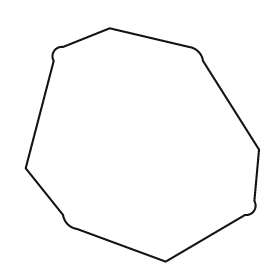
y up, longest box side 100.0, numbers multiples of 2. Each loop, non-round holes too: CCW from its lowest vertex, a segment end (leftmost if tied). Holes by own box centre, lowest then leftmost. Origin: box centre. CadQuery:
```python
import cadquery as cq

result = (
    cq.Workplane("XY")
    .moveTo(10.0, -50.0)
    .lineTo(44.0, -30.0)
    .threePointArc((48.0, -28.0), (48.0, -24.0))
    .lineTo(50.0, -2.0)
    .lineTo(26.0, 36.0)
    .threePointArc((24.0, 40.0), (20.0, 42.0))
    .lineTo(-14.0, 50.0)
    .lineTo(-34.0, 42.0)
    .threePointArc((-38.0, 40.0), (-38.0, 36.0))
    .lineTo(-50.0, -10.0)
    .lineTo(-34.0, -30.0)
    .threePointArc((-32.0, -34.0), (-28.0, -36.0))
    .close()
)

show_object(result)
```